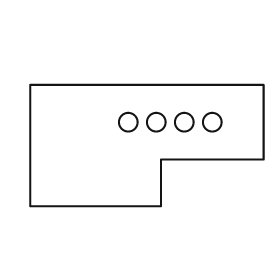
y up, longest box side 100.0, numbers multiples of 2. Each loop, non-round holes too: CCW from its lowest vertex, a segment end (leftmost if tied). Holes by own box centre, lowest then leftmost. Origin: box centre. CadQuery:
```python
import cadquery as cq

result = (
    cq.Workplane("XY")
    .moveTo(-50.0, -26.0)
    .lineTo(6.0, -26.0)
    .lineTo(6.0, -6.0)
    .lineTo(50.0, -6.0)
    .lineTo(50.0, 26.0)
    .lineTo(-50.0, 26.0)
    .close()
    .moveTo(-8.0, 10.0)
    .circle(4.0)
    .moveTo(4.0, 10.0)
    .circle(4.0)
    .moveTo(16.0, 10.0)
    .circle(4.0)
    .moveTo(28.0, 10.0)
    .circle(4.0)
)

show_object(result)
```